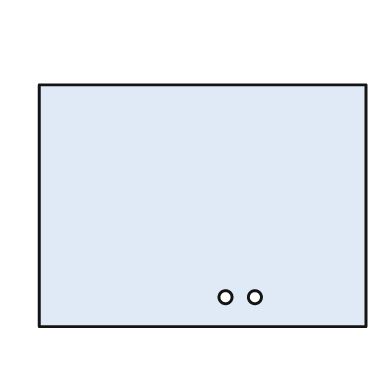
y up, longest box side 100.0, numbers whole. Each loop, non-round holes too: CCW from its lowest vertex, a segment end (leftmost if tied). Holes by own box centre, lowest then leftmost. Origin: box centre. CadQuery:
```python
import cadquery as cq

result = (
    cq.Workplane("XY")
    .moveTo(-50.0, -37.0)
    .lineTo(50.0, -37.0)
    .lineTo(50.0, 37.0)
    .lineTo(-50.0, 37.0)
    .close()
    .moveTo(7.0, -28.0)
    .circle(2.0)
    .moveTo(16.0, -28.0)
    .circle(2.0)
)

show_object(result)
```